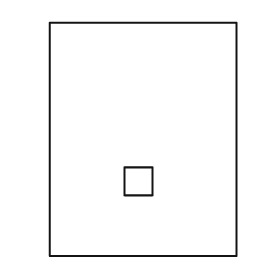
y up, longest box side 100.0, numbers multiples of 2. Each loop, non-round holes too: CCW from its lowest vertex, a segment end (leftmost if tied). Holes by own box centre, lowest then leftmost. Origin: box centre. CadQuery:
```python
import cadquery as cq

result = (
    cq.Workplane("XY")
    .moveTo(-40.0, -50.0)
    .lineTo(40.0, -50.0)
    .lineTo(40.0, 50.0)
    .lineTo(-40.0, 50.0)
    .close()
    .moveTo(-8.0, -24.0)
    .lineTo(4.0, -24.0)
    .lineTo(4.0, -12.0)
    .lineTo(-8.0, -12.0)
    .close()
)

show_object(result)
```